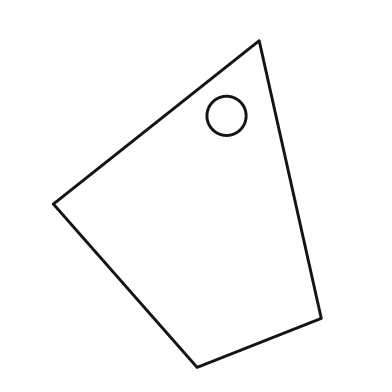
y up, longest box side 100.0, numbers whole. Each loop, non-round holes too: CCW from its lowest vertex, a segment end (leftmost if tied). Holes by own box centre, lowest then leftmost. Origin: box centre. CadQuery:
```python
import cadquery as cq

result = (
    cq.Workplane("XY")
    .moveTo(3.0, -50.0)
    .lineTo(41.0, -35.0)
    .lineTo(22.0, 50.0)
    .lineTo(-41.0, 0.0)
    .close()
    .moveTo(12.0, 27.0)
    .circle(6.0)
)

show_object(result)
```